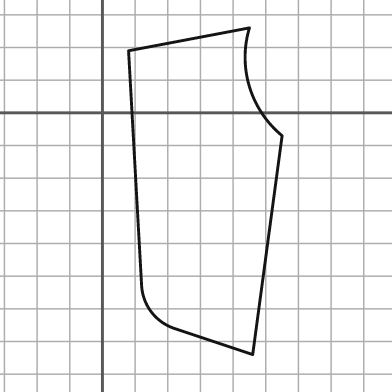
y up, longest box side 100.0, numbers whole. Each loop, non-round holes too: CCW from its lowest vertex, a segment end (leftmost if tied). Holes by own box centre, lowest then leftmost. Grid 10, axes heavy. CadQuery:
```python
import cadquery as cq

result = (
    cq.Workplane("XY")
    .moveTo(46.0, -74.0)
    .lineTo(55.0, -7.0)
    .threePointArc((45.0, 8.0), (45.0, 26.0))
    .lineTo(8.0, 19.0)
    .lineTo(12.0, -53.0)
    .threePointArc((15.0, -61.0), (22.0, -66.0))
    .close()
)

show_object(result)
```